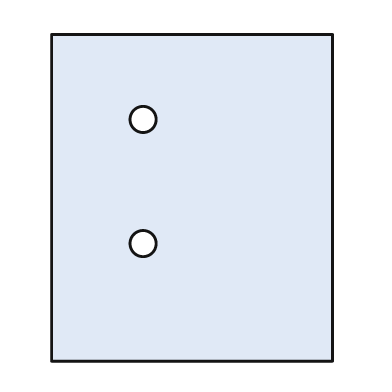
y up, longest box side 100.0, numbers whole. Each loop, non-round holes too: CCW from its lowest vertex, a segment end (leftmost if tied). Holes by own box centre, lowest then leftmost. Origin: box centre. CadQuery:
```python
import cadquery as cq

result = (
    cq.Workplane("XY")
    .moveTo(-43.0, -50.0)
    .lineTo(43.0, -50.0)
    .lineTo(43.0, 50.0)
    .lineTo(-43.0, 50.0)
    .close()
    .moveTo(-15.0, -14.0)
    .circle(4.0)
    .moveTo(-15.0, 24.0)
    .circle(4.0)
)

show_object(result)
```